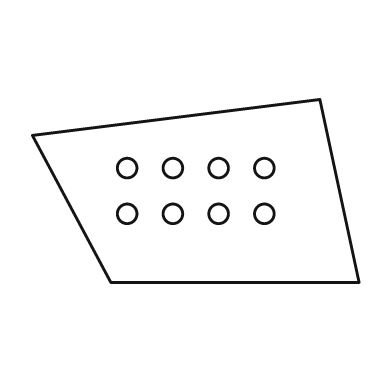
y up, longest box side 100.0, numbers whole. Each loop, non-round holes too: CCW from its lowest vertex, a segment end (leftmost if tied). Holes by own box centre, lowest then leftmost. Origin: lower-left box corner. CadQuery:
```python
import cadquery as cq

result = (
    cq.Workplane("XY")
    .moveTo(24.0, 0.0)
    .lineTo(100.0, 0.0)
    .lineTo(88.0, 56.0)
    .lineTo(0.0, 45.0)
    .close()
    .moveTo(29.0, 21.0)
    .circle(3.0)
    .moveTo(43.0, 21.0)
    .circle(3.0)
    .moveTo(57.0, 21.0)
    .circle(3.0)
    .moveTo(71.0, 21.0)
    .circle(3.0)
    .moveTo(29.0, 35.0)
    .circle(3.0)
    .moveTo(43.0, 35.0)
    .circle(3.0)
    .moveTo(57.0, 35.0)
    .circle(3.0)
    .moveTo(71.0, 35.0)
    .circle(3.0)
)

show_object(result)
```